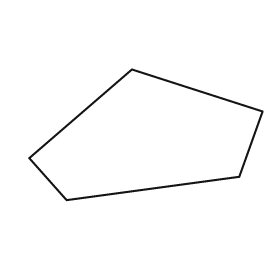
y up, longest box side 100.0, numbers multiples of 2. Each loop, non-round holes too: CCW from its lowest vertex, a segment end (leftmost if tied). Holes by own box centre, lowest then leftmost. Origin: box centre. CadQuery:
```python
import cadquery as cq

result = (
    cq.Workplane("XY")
    .moveTo(-34.0, -28.0)
    .lineTo(40.0, -18.0)
    .lineTo(50.0, 10.0)
    .lineTo(-6.0, 28.0)
    .lineTo(-50.0, -10.0)
    .close()
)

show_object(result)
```